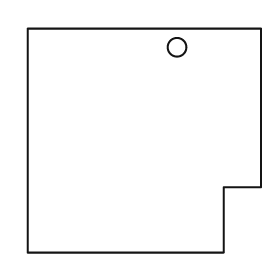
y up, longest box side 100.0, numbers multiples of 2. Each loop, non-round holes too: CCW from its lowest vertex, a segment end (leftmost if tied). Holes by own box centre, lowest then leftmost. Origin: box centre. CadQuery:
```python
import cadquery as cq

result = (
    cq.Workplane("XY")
    .moveTo(-50.0, -48.0)
    .lineTo(34.0, -48.0)
    .lineTo(34.0, -20.0)
    .lineTo(50.0, -20.0)
    .lineTo(50.0, 48.0)
    .lineTo(-50.0, 48.0)
    .close()
    .moveTo(14.0, 40.0)
    .circle(4.0)
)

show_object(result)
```